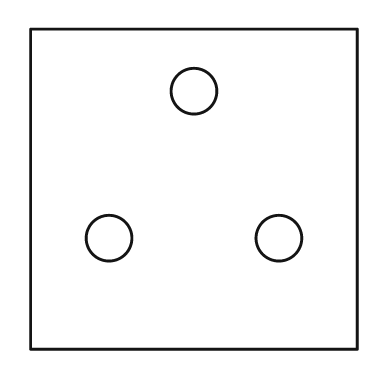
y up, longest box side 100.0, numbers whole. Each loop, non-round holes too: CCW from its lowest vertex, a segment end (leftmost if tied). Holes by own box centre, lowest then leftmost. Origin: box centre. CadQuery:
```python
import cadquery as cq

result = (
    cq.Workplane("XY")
    .moveTo(-50.0, -49.0)
    .lineTo(50.0, -49.0)
    .lineTo(50.0, 49.0)
    .lineTo(-50.0, 49.0)
    .close()
    .moveTo(-26.0, -15.0)
    .circle(7.0)
    .moveTo(26.0, -15.0)
    .circle(7.0)
    .moveTo(0.0, 30.0)
    .circle(7.0)
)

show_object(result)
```